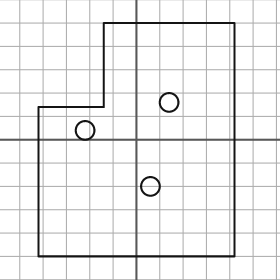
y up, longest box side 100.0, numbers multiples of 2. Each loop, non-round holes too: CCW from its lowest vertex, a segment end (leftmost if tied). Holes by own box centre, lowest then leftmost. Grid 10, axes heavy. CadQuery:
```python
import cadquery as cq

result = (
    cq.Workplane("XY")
    .moveTo(-42.0, -50.0)
    .lineTo(42.0, -50.0)
    .lineTo(42.0, 50.0)
    .lineTo(-14.0, 50.0)
    .lineTo(-14.0, 14.0)
    .lineTo(-42.0, 14.0)
    .close()
    .moveTo(6.0, -20.0)
    .circle(4.0)
    .moveTo(-22.0, 4.0)
    .circle(4.0)
    .moveTo(14.0, 16.0)
    .circle(4.0)
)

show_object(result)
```